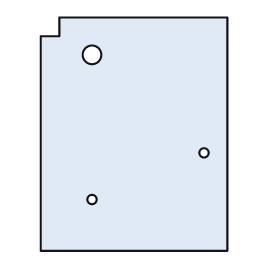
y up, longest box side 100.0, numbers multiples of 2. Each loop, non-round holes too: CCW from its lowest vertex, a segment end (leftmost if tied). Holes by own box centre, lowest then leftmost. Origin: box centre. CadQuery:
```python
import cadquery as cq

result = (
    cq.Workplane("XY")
    .moveTo(-40.0, -50.0)
    .lineTo(40.0, -50.0)
    .lineTo(40.0, 50.0)
    .lineTo(-32.0, 50.0)
    .lineTo(-32.0, 42.0)
    .lineTo(-40.0, 42.0)
    .close()
    .moveTo(-18.0, -28.0)
    .circle(2.0)
    .moveTo(30.0, -8.0)
    .circle(2.0)
    .moveTo(-18.0, 34.0)
    .circle(4.0)
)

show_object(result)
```